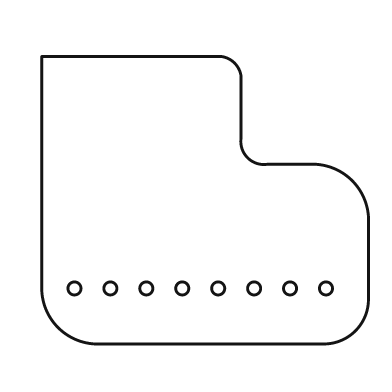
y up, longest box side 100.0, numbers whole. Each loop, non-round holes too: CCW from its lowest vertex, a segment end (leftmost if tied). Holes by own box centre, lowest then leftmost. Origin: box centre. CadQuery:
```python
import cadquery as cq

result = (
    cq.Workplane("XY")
    .moveTo(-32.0, -44.0)
    .lineTo(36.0, -44.0)
    .threePointArc((46.0, -40.0), (50.0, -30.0))
    .lineTo(50.0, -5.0)
    .threePointArc((45.0, 6.0), (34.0, 11.0))
    .lineTo(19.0, 11.0)
    .threePointArc((13.0, 13.0), (11.0, 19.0))
    .lineTo(11.0, 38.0)
    .threePointArc((9.0, 42.0), (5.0, 44.0))
    .lineTo(-50.0, 44.0)
    .lineTo(-50.0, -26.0)
    .threePointArc((-45.0, -39.0), (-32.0, -44.0))
    .close()
    .moveTo(-40.0, -27.0)
    .circle(2.0)
    .moveTo(-29.0, -27.0)
    .circle(2.0)
    .moveTo(-18.0, -27.0)
    .circle(2.0)
    .moveTo(-7.0, -27.0)
    .circle(2.0)
    .moveTo(4.0, -27.0)
    .circle(2.0)
    .moveTo(15.0, -27.0)
    .circle(2.0)
    .moveTo(26.0, -27.0)
    .circle(2.0)
    .moveTo(37.0, -27.0)
    .circle(2.0)
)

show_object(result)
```